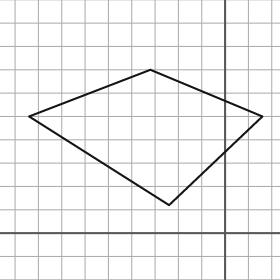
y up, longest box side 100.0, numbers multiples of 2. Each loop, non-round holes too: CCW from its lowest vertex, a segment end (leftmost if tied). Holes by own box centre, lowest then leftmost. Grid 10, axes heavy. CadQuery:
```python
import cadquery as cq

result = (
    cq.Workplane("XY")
    .moveTo(-24.0, 12.0)
    .lineTo(16.0, 50.0)
    .lineTo(-32.0, 70.0)
    .lineTo(-84.0, 50.0)
    .close()
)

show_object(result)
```